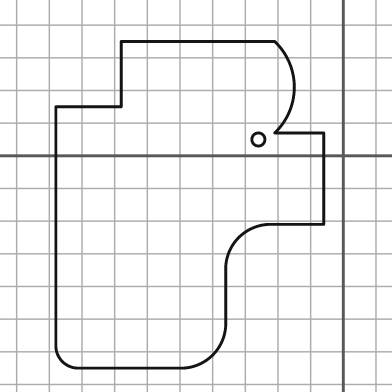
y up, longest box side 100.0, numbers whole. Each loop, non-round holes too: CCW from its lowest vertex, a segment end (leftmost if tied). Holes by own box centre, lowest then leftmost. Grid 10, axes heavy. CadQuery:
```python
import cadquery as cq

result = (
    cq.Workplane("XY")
    .moveTo(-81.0, -65.0)
    .lineTo(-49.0, -65.0)
    .threePointArc((-40.0, -61.0), (-36.0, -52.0))
    .lineTo(-36.0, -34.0)
    .threePointArc((-32.0, -25.0), (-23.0, -21.0))
    .lineTo(-6.0, -21.0)
    .lineTo(-6.0, 7.0)
    .lineTo(-21.0, 7.0)
    .threePointArc((-15.0, 21.0), (-21.0, 35.0))
    .lineTo(-68.0, 35.0)
    .lineTo(-68.0, 15.0)
    .lineTo(-88.0, 15.0)
    .lineTo(-88.0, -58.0)
    .threePointArc((-86.0, -63.0), (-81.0, -65.0))
    .close()
    .moveTo(-26.0, 5.0)
    .circle(2.0)
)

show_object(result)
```